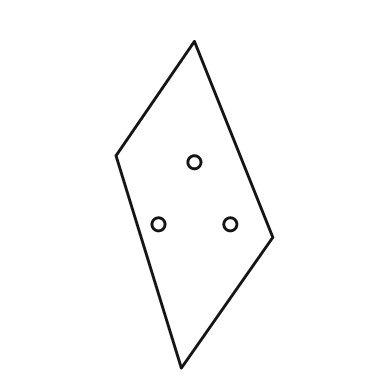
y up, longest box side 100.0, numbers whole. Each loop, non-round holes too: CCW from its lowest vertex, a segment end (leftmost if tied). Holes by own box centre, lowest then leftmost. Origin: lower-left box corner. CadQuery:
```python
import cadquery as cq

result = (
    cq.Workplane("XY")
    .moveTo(20.0, 0.0)
    .lineTo(48.0, 40.0)
    .lineTo(24.0, 100.0)
    .lineTo(0.0, 65.0)
    .close()
    .moveTo(13.0, 44.0)
    .circle(2.0)
    .moveTo(35.0, 44.0)
    .circle(2.0)
    .moveTo(24.0, 63.0)
    .circle(2.0)
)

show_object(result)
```